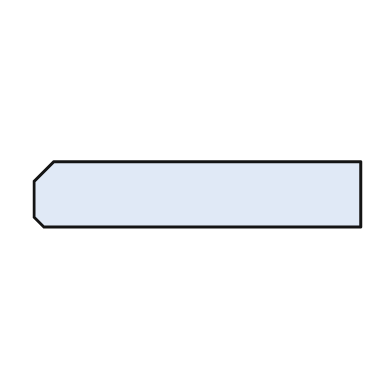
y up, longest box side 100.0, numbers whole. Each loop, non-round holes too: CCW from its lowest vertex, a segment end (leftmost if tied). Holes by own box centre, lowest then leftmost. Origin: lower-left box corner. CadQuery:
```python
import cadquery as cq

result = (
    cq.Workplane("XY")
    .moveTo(3.0, 0.0)
    .lineTo(100.0, 0.0)
    .lineTo(100.0, 20.0)
    .lineTo(6.0, 20.0)
    .lineTo(0.0, 14.0)
    .lineTo(0.0, 3.0)
    .close()
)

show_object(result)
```